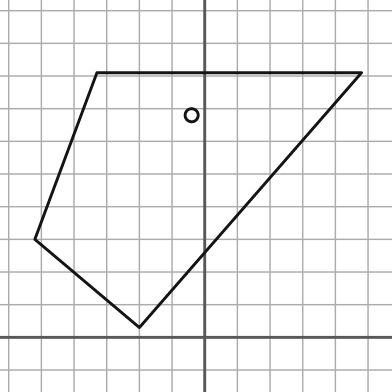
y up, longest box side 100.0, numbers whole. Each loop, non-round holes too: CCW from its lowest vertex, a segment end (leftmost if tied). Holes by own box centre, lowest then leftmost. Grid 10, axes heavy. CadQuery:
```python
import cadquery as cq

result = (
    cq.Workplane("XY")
    .moveTo(-20.0, 3.0)
    .lineTo(48.0, 81.0)
    .lineTo(-33.0, 81.0)
    .lineTo(-52.0, 30.0)
    .close()
    .moveTo(-4.0, 68.0)
    .circle(2.0)
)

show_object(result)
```